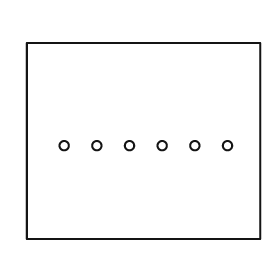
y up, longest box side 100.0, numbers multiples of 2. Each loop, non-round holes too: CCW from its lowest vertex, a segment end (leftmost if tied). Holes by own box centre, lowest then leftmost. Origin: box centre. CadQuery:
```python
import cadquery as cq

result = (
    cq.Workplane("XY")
    .moveTo(-50.0, -42.0)
    .lineTo(50.0, -42.0)
    .lineTo(50.0, 42.0)
    .lineTo(-50.0, 42.0)
    .close()
    .moveTo(-34.0, -2.0)
    .circle(2.0)
    .moveTo(-20.0, -2.0)
    .circle(2.0)
    .moveTo(-6.0, -2.0)
    .circle(2.0)
    .moveTo(8.0, -2.0)
    .circle(2.0)
    .moveTo(22.0, -2.0)
    .circle(2.0)
    .moveTo(36.0, -2.0)
    .circle(2.0)
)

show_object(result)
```